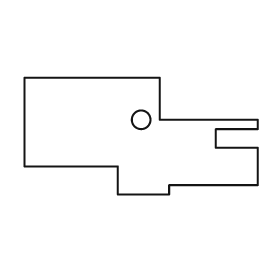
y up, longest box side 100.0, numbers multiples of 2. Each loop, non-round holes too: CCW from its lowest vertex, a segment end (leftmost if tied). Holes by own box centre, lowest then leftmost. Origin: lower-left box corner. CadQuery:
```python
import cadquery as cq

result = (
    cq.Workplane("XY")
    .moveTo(40.0, 0.0)
    .lineTo(62.0, 0.0)
    .lineTo(62.0, 4.0)
    .lineTo(100.0, 4.0)
    .lineTo(100.0, 20.0)
    .lineTo(82.0, 20.0)
    .lineTo(82.0, 28.0)
    .lineTo(100.0, 28.0)
    .lineTo(100.0, 32.0)
    .lineTo(58.0, 32.0)
    .lineTo(58.0, 50.0)
    .lineTo(0.0, 50.0)
    .lineTo(0.0, 12.0)
    .lineTo(40.0, 12.0)
    .close()
    .moveTo(50.0, 32.0)
    .circle(4.0)
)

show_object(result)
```